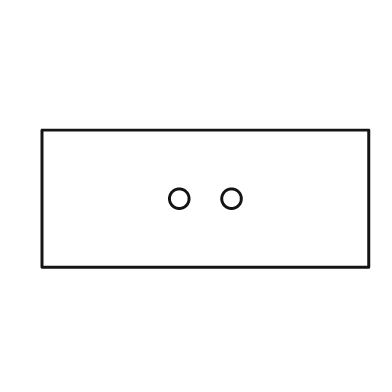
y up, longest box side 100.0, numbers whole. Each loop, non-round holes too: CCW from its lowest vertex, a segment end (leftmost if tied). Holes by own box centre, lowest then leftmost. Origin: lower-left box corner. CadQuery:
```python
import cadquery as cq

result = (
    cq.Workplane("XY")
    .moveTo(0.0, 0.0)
    .lineTo(100.0, 0.0)
    .lineTo(100.0, 42.0)
    .lineTo(0.0, 42.0)
    .close()
    .moveTo(42.0, 21.0)
    .circle(3.0)
    .moveTo(58.0, 21.0)
    .circle(3.0)
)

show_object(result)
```